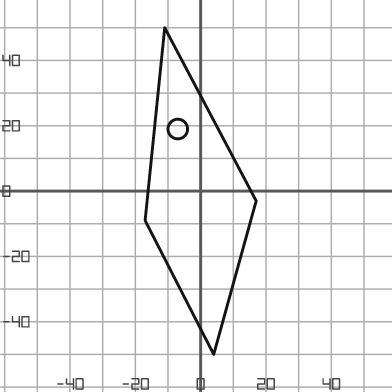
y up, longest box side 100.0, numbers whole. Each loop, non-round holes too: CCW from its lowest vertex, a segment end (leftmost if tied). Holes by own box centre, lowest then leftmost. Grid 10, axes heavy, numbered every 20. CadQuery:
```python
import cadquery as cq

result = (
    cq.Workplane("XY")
    .moveTo(4.0, -50.0)
    .lineTo(17.0, -3.0)
    .lineTo(-11.0, 50.0)
    .lineTo(-17.0, -9.0)
    .close()
    .moveTo(-7.0, 19.0)
    .circle(3.0)
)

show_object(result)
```